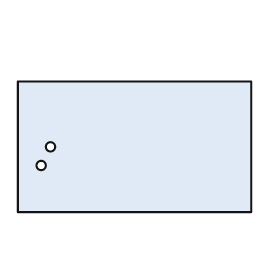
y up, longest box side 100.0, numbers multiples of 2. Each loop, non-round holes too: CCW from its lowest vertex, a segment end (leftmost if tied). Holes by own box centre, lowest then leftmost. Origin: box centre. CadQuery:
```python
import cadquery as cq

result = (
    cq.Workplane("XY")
    .moveTo(-50.0, -28.0)
    .lineTo(50.0, -28.0)
    .lineTo(50.0, 28.0)
    .lineTo(-50.0, 28.0)
    .close()
    .moveTo(-40.0, -8.0)
    .circle(2.0)
    .moveTo(-36.0, 0.0)
    .circle(2.0)
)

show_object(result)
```